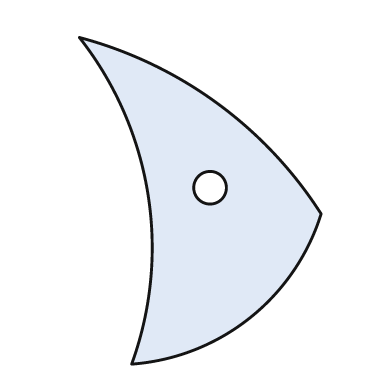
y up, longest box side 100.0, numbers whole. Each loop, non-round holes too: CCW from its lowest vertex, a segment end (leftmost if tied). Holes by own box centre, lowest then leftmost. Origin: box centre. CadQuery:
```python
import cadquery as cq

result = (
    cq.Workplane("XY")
    .moveTo(-21.0, -50.0)
    .threePointArc((15.0, -36.0), (37.0, -4.0))
    .threePointArc((5.0, 30.0), (-37.0, 50.0))
    .threePointArc((-16.0, 2.0), (-21.0, -50.0))
    .close()
    .moveTo(3.0, 4.0)
    .circle(5.0)
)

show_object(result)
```